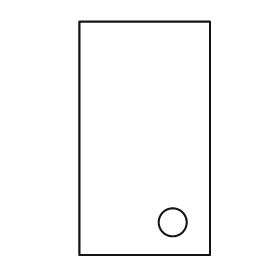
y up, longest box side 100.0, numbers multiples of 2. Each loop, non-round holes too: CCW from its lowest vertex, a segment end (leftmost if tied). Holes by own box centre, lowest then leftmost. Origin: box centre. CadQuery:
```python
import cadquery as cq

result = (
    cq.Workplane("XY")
    .moveTo(-28.0, -50.0)
    .lineTo(28.0, -50.0)
    .lineTo(28.0, 50.0)
    .lineTo(-28.0, 50.0)
    .close()
    .moveTo(12.0, -36.0)
    .circle(6.0)
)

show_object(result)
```